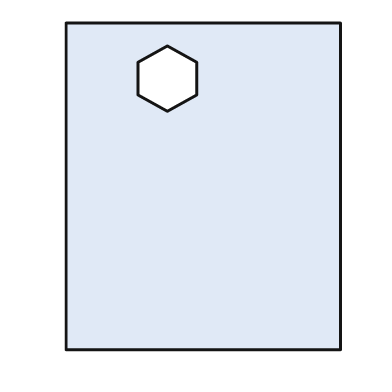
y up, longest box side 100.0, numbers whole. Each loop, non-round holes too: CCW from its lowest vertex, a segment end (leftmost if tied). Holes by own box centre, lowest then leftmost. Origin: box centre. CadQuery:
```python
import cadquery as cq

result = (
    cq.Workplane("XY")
    .moveTo(-42.0, -50.0)
    .lineTo(42.0, -50.0)
    .lineTo(42.0, 50.0)
    .lineTo(-42.0, 50.0)
    .close()
    .moveTo(-11.0, 23.0)
    .lineTo(-2.0, 28.0)
    .lineTo(-2.0, 38.0)
    .lineTo(-11.0, 43.0)
    .lineTo(-20.0, 38.0)
    .lineTo(-20.0, 28.0)
    .close()
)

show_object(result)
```